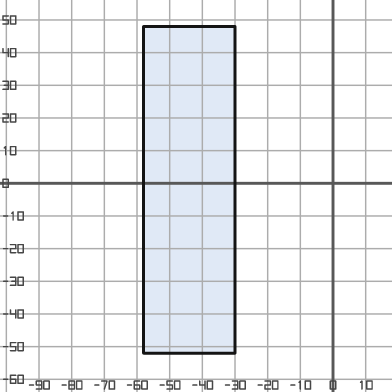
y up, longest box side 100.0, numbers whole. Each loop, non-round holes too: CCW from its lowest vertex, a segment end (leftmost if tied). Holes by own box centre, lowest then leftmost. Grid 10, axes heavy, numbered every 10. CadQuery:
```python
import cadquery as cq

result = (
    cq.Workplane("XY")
    .moveTo(-58.0, -52.0)
    .lineTo(-30.0, -52.0)
    .lineTo(-30.0, 48.0)
    .lineTo(-58.0, 48.0)
    .close()
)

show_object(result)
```